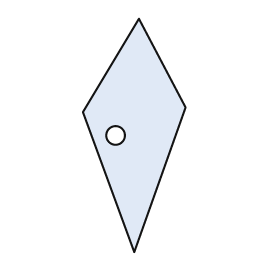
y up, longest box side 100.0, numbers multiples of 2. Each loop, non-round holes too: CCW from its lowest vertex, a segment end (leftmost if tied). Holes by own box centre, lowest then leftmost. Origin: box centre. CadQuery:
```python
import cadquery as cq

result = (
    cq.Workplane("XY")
    .moveTo(0.0, -50.0)
    .lineTo(22.0, 12.0)
    .lineTo(2.0, 50.0)
    .lineTo(-22.0, 10.0)
    .close()
    .moveTo(-8.0, 0.0)
    .circle(4.0)
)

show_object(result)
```